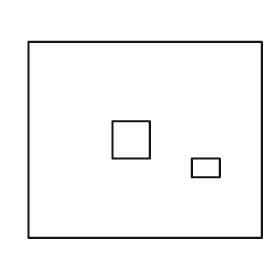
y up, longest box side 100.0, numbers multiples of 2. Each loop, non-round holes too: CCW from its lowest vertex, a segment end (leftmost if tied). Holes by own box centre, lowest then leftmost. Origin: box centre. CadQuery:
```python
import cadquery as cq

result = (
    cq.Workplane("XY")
    .moveTo(-50.0, -42.0)
    .lineTo(50.0, -42.0)
    .lineTo(50.0, 42.0)
    .lineTo(-50.0, 42.0)
    .close()
    .moveTo(20.0, -16.0)
    .lineTo(32.0, -16.0)
    .lineTo(32.0, -8.0)
    .lineTo(20.0, -8.0)
    .close()
    .moveTo(-14.0, -8.0)
    .lineTo(2.0, -8.0)
    .lineTo(2.0, 8.0)
    .lineTo(-14.0, 8.0)
    .close()
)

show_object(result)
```